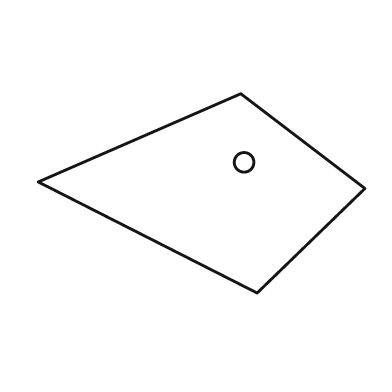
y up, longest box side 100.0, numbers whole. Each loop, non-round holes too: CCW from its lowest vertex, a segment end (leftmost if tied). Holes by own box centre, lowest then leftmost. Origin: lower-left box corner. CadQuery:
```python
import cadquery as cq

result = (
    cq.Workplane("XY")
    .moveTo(67.0, 0.0)
    .lineTo(100.0, 32.0)
    .lineTo(62.0, 61.0)
    .lineTo(0.0, 34.0)
    .close()
    .moveTo(63.0, 40.0)
    .circle(3.0)
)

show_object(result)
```